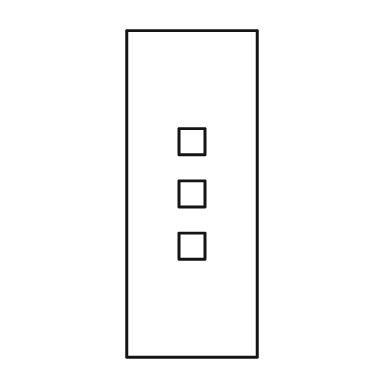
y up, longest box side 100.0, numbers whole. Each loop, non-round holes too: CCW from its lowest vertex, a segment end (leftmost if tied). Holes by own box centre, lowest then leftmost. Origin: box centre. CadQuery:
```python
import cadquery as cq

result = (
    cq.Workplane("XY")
    .moveTo(-20.0, -50.0)
    .lineTo(20.0, -50.0)
    .lineTo(20.0, 50.0)
    .lineTo(-20.0, 50.0)
    .close()
    .moveTo(-4.0, -20.0)
    .lineTo(4.0, -20.0)
    .lineTo(4.0, -12.0)
    .lineTo(-4.0, -12.0)
    .close()
    .moveTo(-4.0, -4.0)
    .lineTo(4.0, -4.0)
    .lineTo(4.0, 4.0)
    .lineTo(-4.0, 4.0)
    .close()
    .moveTo(-4.0, 12.0)
    .lineTo(4.0, 12.0)
    .lineTo(4.0, 20.0)
    .lineTo(-4.0, 20.0)
    .close()
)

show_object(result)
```